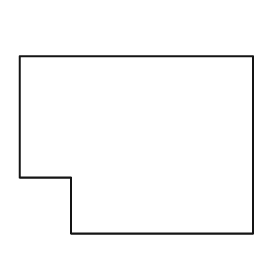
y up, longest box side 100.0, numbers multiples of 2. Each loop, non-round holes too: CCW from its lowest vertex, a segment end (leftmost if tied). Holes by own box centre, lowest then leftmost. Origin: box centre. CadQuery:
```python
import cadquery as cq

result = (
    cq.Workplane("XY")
    .moveTo(-28.0, -38.0)
    .lineTo(50.0, -38.0)
    .lineTo(50.0, 38.0)
    .lineTo(-50.0, 38.0)
    .lineTo(-50.0, -14.0)
    .lineTo(-28.0, -14.0)
    .close()
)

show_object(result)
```